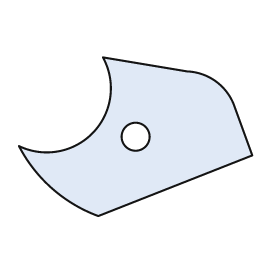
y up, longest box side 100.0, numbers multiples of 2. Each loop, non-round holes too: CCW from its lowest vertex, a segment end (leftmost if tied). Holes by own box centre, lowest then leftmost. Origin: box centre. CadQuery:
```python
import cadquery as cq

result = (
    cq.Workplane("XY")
    .moveTo(-16.0, -34.0)
    .lineTo(50.0, -8.0)
    .lineTo(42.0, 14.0)
    .threePointArc((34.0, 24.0), (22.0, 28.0))
    .lineTo(-14.0, 34.0)
    .threePointArc((-18.0, 2.0), (-50.0, -4.0))
    .threePointArc((-36.0, -22.0), (-16.0, -34.0))
    .close()
    .moveTo(0.0, 0.0)
    .circle(6.0)
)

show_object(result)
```